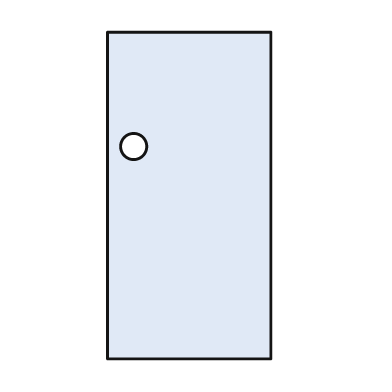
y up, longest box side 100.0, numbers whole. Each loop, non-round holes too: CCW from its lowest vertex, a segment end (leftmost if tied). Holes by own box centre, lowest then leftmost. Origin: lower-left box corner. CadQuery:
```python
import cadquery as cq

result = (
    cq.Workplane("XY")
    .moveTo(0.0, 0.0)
    .lineTo(50.0, 0.0)
    .lineTo(50.0, 100.0)
    .lineTo(0.0, 100.0)
    .close()
    .moveTo(8.0, 65.0)
    .circle(4.0)
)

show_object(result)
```